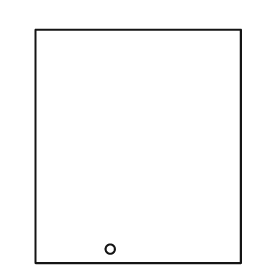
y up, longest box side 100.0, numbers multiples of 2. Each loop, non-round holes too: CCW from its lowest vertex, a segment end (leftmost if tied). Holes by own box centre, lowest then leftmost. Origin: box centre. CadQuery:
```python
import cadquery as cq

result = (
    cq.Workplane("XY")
    .moveTo(-44.0, -50.0)
    .lineTo(44.0, -50.0)
    .lineTo(44.0, 50.0)
    .lineTo(-44.0, 50.0)
    .close()
    .moveTo(-12.0, -44.0)
    .circle(2.0)
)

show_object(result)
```